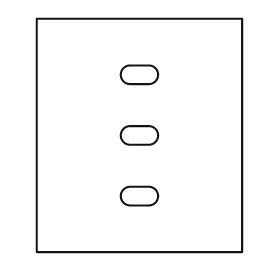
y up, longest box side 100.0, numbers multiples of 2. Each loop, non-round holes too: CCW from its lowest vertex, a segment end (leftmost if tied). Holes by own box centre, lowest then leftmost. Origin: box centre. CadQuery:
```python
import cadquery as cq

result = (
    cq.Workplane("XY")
    .moveTo(-44.0, -50.0)
    .lineTo(44.0, -50.0)
    .lineTo(44.0, 50.0)
    .lineTo(-44.0, 50.0)
    .close()
    .moveTo(-4.0, -30.0)
    .lineTo(4.0, -30.0)
    .threePointArc((8.0, -26.0), (4.0, -22.0))
    .lineTo(-4.0, -22.0)
    .threePointArc((-8.0, -26.0), (-4.0, -30.0))
    .close()
    .moveTo(-4.0, -4.0)
    .lineTo(4.0, -4.0)
    .threePointArc((8.0, 0.0), (4.0, 4.0))
    .lineTo(-4.0, 4.0)
    .threePointArc((-8.0, 0.0), (-4.0, -4.0))
    .close()
    .moveTo(-4.0, 22.0)
    .lineTo(4.0, 22.0)
    .threePointArc((8.0, 26.0), (4.0, 30.0))
    .lineTo(-4.0, 30.0)
    .threePointArc((-8.0, 26.0), (-4.0, 22.0))
    .close()
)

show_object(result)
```